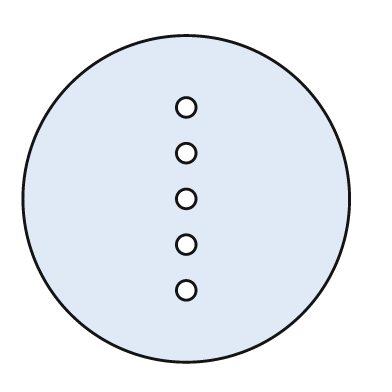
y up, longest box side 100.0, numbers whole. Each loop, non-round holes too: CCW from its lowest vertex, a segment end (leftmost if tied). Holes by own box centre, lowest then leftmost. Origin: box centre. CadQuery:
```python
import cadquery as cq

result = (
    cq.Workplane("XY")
    .moveTo(0.0, 0.0)
    .circle(50.0)
    .moveTo(0.0, -28.0)
    .circle(3.0)
    .moveTo(0.0, -14.0)
    .circle(3.0)
    .moveTo(0.0, 0.0)
    .circle(3.0)
    .moveTo(0.0, 14.0)
    .circle(3.0)
    .moveTo(0.0, 28.0)
    .circle(3.0)
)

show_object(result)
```